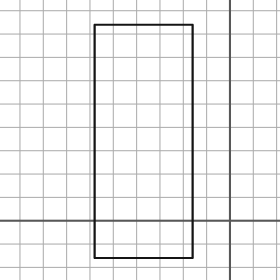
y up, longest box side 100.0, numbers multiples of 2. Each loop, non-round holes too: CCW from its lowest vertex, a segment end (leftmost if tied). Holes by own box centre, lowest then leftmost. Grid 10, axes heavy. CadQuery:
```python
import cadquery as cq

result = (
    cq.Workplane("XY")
    .moveTo(-58.0, -16.0)
    .lineTo(-16.0, -16.0)
    .lineTo(-16.0, 84.0)
    .lineTo(-58.0, 84.0)
    .close()
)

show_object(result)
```